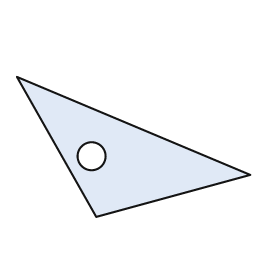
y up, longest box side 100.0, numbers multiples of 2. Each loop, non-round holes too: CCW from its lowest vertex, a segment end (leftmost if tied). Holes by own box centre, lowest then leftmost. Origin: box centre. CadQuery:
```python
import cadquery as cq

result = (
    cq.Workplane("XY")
    .moveTo(-16.0, -30.0)
    .lineTo(50.0, -12.0)
    .lineTo(-50.0, 30.0)
    .close()
    .moveTo(-18.0, -4.0)
    .circle(6.0)
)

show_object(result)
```